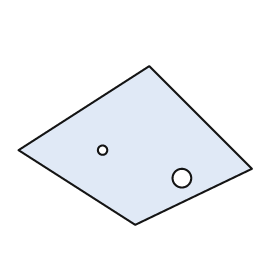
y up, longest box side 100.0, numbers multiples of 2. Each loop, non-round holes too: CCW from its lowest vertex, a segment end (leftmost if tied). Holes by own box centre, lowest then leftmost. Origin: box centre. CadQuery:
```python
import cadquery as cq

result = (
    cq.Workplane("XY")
    .moveTo(0.0, -34.0)
    .lineTo(50.0, -10.0)
    .lineTo(6.0, 34.0)
    .lineTo(-50.0, -2.0)
    .close()
    .moveTo(20.0, -14.0)
    .circle(4.0)
    .moveTo(-14.0, -2.0)
    .circle(2.0)
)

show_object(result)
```